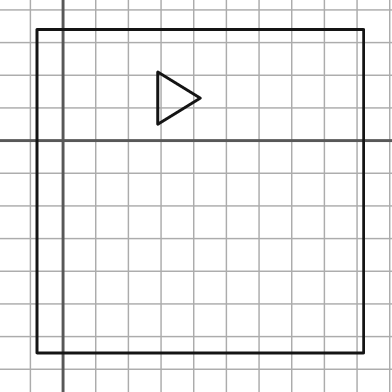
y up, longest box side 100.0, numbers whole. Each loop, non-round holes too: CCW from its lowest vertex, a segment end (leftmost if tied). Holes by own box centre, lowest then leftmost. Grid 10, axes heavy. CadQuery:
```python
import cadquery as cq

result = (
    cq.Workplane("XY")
    .moveTo(-8.0, -65.0)
    .lineTo(92.0, -65.0)
    .lineTo(92.0, 34.0)
    .lineTo(-8.0, 34.0)
    .close()
    .moveTo(29.0, 5.0)
    .lineTo(42.0, 13.0)
    .lineTo(29.0, 21.0)
    .close()
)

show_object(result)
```